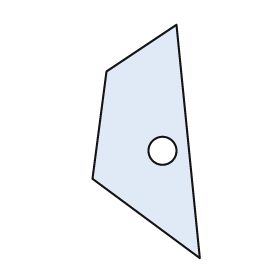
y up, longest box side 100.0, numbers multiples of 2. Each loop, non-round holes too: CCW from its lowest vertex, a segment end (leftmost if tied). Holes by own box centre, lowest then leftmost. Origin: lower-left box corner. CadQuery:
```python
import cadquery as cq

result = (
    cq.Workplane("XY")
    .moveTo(46.0, 0.0)
    .lineTo(36.0, 100.0)
    .lineTo(6.0, 80.0)
    .lineTo(0.0, 34.0)
    .close()
    .moveTo(30.0, 46.0)
    .circle(6.0)
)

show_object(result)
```